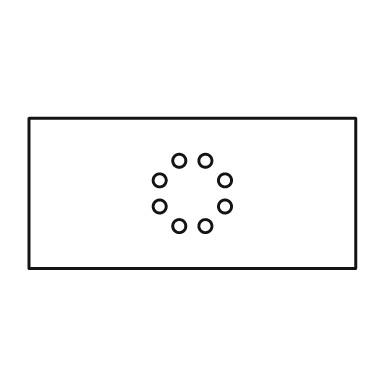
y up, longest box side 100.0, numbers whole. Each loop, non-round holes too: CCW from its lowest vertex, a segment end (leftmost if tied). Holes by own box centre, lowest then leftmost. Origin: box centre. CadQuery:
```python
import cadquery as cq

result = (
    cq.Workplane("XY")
    .moveTo(-50.0, -23.0)
    .lineTo(50.0, -23.0)
    .lineTo(50.0, 23.0)
    .lineTo(-50.0, 23.0)
    .close()
    .moveTo(-4.0, -10.0)
    .circle(2.0)
    .moveTo(4.0, -10.0)
    .circle(2.0)
    .moveTo(-10.0, -4.0)
    .circle(2.0)
    .moveTo(10.0, -4.0)
    .circle(2.0)
    .moveTo(-10.0, 4.0)
    .circle(2.0)
    .moveTo(10.0, 4.0)
    .circle(2.0)
    .moveTo(-4.0, 10.0)
    .circle(2.0)
    .moveTo(4.0, 10.0)
    .circle(2.0)
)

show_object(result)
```